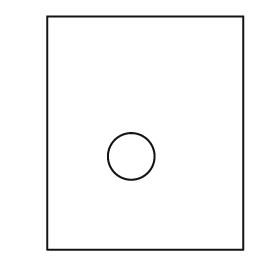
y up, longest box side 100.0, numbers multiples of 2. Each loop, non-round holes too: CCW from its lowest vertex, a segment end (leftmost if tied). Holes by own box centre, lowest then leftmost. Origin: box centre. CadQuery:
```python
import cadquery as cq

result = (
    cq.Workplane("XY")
    .moveTo(-42.0, -50.0)
    .lineTo(42.0, -50.0)
    .lineTo(42.0, 50.0)
    .lineTo(-42.0, 50.0)
    .close()
    .moveTo(-6.0, -10.0)
    .circle(10.0)
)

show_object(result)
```